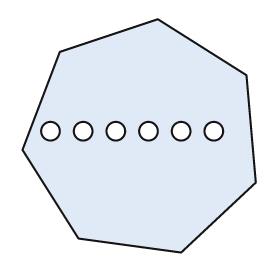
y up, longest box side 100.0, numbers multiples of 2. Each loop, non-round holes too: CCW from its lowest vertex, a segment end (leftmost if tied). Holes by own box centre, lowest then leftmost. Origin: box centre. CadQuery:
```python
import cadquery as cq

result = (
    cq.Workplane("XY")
    .moveTo(18.0, -50.0)
    .lineTo(50.0, -20.0)
    .lineTo(46.0, 26.0)
    .lineTo(8.0, 50.0)
    .lineTo(-34.0, 36.0)
    .lineTo(-50.0, -6.0)
    .lineTo(-26.0, -44.0)
    .close()
    .moveTo(-38.0, 2.0)
    .circle(4.0)
    .moveTo(-24.0, 2.0)
    .circle(4.0)
    .moveTo(-10.0, 2.0)
    .circle(4.0)
    .moveTo(4.0, 2.0)
    .circle(4.0)
    .moveTo(18.0, 2.0)
    .circle(4.0)
    .moveTo(32.0, 2.0)
    .circle(4.0)
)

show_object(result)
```